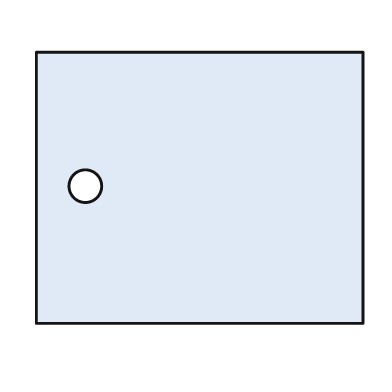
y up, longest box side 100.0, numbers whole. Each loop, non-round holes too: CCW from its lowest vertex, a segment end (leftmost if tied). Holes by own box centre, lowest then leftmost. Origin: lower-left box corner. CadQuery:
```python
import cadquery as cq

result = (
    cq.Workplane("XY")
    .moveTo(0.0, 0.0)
    .lineTo(100.0, 0.0)
    .lineTo(100.0, 83.0)
    .lineTo(0.0, 83.0)
    .close()
    .moveTo(15.0, 42.0)
    .circle(5.0)
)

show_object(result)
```